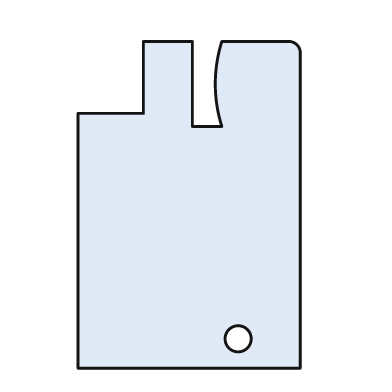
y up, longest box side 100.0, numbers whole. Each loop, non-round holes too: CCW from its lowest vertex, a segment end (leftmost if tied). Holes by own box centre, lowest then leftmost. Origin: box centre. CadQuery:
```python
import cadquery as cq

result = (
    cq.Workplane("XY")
    .moveTo(-34.0, -50.0)
    .lineTo(34.0, -50.0)
    .lineTo(34.0, 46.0)
    .threePointArc((33.0, 49.0), (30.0, 50.0))
    .lineTo(10.0, 50.0)
    .threePointArc((8.0, 37.0), (10.0, 24.0))
    .lineTo(1.0, 24.0)
    .lineTo(1.0, 50.0)
    .lineTo(-14.0, 50.0)
    .lineTo(-14.0, 28.0)
    .lineTo(-34.0, 28.0)
    .close()
    .moveTo(15.0, -41.0)
    .circle(4.0)
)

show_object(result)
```